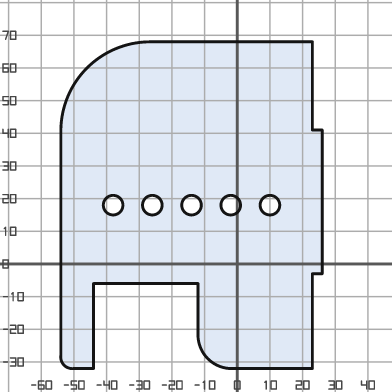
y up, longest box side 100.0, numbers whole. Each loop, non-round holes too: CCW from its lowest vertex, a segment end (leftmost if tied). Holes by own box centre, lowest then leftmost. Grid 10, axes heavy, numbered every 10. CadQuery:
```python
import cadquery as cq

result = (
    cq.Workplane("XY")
    .moveTo(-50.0, -32.0)
    .lineTo(-44.0, -32.0)
    .lineTo(-44.0, -6.0)
    .lineTo(-12.0, -6.0)
    .lineTo(-12.0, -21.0)
    .threePointArc((-9.0, -29.0), (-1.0, -32.0))
    .lineTo(23.0, -32.0)
    .lineTo(23.0, -3.0)
    .lineTo(26.0, -3.0)
    .lineTo(26.0, 41.0)
    .lineTo(23.0, 41.0)
    .lineTo(23.0, 68.0)
    .lineTo(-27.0, 68.0)
    .threePointArc((-46.0, 60.0), (-54.0, 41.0))
    .lineTo(-54.0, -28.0)
    .threePointArc((-53.0, -31.0), (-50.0, -32.0))
    .close()
    .moveTo(-38.0, 18.0)
    .circle(3.0)
    .moveTo(-26.0, 18.0)
    .circle(3.0)
    .moveTo(-14.0, 18.0)
    .circle(3.0)
    .moveTo(-2.0, 18.0)
    .circle(3.0)
    .moveTo(10.0, 18.0)
    .circle(3.0)
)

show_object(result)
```